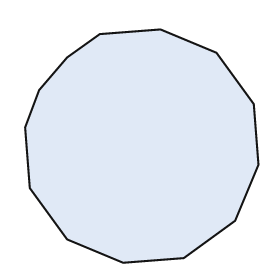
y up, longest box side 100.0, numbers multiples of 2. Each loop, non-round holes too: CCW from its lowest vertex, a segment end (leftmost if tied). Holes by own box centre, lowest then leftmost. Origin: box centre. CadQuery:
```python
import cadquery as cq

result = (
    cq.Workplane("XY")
    .moveTo(-8.0, -50.0)
    .lineTo(18.0, -48.0)
    .lineTo(40.0, -32.0)
    .lineTo(50.0, -8.0)
    .lineTo(48.0, 18.0)
    .lineTo(32.0, 40.0)
    .lineTo(8.0, 50.0)
    .lineTo(-18.0, 48.0)
    .lineTo(-32.0, 38.0)
    .lineTo(-44.0, 24.0)
    .lineTo(-50.0, 8.0)
    .lineTo(-48.0, -18.0)
    .lineTo(-32.0, -40.0)
    .close()
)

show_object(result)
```